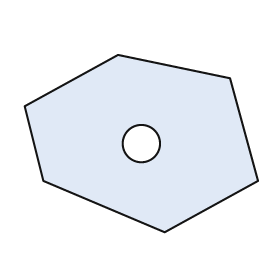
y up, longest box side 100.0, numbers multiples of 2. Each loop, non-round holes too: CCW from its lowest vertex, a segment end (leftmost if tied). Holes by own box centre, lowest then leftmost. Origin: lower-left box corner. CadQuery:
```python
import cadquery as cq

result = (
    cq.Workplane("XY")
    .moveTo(60.0, 0.0)
    .lineTo(100.0, 22.0)
    .lineTo(88.0, 66.0)
    .lineTo(40.0, 76.0)
    .lineTo(0.0, 54.0)
    .lineTo(8.0, 22.0)
    .close()
    .moveTo(50.0, 38.0)
    .circle(8.0)
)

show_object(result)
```